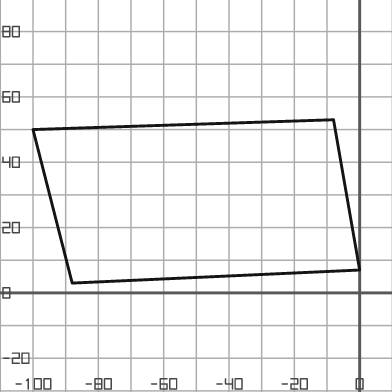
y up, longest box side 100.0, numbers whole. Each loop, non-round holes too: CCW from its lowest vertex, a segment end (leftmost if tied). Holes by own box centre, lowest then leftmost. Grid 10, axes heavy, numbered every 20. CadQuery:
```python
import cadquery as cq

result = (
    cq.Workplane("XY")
    .moveTo(-88.0, 3.0)
    .lineTo(0.0, 7.0)
    .lineTo(-8.0, 53.0)
    .lineTo(-100.0, 50.0)
    .close()
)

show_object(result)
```